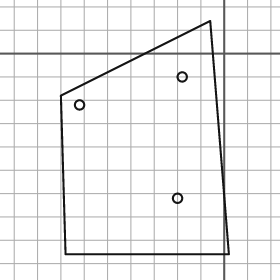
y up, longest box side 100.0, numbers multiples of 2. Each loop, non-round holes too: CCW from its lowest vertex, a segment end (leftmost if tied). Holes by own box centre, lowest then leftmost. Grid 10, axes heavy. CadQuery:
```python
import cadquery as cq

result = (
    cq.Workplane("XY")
    .moveTo(-68.0, -86.0)
    .lineTo(2.0, -86.0)
    .lineTo(-6.0, 14.0)
    .lineTo(-70.0, -18.0)
    .close()
    .moveTo(-20.0, -62.0)
    .circle(2.0)
    .moveTo(-62.0, -22.0)
    .circle(2.0)
    .moveTo(-18.0, -10.0)
    .circle(2.0)
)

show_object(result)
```